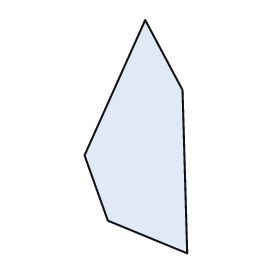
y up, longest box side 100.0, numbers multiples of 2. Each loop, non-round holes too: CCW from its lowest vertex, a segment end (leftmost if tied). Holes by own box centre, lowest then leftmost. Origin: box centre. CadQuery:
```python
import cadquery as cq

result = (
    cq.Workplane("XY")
    .moveTo(22.0, -50.0)
    .lineTo(20.0, 20.0)
    .lineTo(4.0, 50.0)
    .lineTo(-22.0, -8.0)
    .lineTo(-12.0, -36.0)
    .close()
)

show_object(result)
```